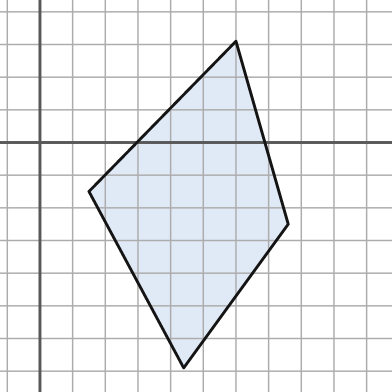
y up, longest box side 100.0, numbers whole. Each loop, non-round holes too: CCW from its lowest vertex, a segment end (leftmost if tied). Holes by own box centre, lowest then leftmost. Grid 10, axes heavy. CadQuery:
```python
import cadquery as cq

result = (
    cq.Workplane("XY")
    .moveTo(44.0, -69.0)
    .lineTo(76.0, -25.0)
    .lineTo(60.0, 31.0)
    .lineTo(15.0, -15.0)
    .close()
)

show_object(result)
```